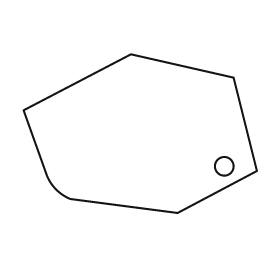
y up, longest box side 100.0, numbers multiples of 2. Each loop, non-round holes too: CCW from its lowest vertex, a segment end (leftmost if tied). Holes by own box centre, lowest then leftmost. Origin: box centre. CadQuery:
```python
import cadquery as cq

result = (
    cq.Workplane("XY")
    .moveTo(16.0, -34.0)
    .lineTo(50.0, -16.0)
    .lineTo(40.0, 24.0)
    .lineTo(-4.0, 34.0)
    .lineTo(-50.0, 10.0)
    .lineTo(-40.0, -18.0)
    .threePointArc((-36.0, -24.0), (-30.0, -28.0))
    .close()
    .moveTo(36.0, -14.0)
    .circle(4.0)
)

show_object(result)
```